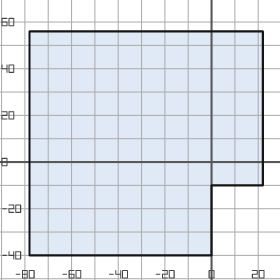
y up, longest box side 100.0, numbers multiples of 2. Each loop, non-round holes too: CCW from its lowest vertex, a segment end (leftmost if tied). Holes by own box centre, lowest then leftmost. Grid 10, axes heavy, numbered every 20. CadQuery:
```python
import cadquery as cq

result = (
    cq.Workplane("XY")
    .moveTo(-78.0, -40.0)
    .lineTo(0.0, -40.0)
    .lineTo(0.0, -10.0)
    .lineTo(22.0, -10.0)
    .lineTo(22.0, 56.0)
    .lineTo(-78.0, 56.0)
    .close()
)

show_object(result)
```